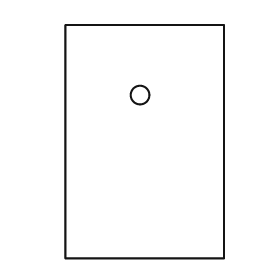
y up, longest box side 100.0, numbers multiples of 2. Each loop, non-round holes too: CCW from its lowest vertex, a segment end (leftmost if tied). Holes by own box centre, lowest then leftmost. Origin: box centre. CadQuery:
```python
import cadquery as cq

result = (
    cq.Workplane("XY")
    .moveTo(-34.0, -50.0)
    .lineTo(34.0, -50.0)
    .lineTo(34.0, 50.0)
    .lineTo(-34.0, 50.0)
    .close()
    .moveTo(-2.0, 20.0)
    .circle(4.0)
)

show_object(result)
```